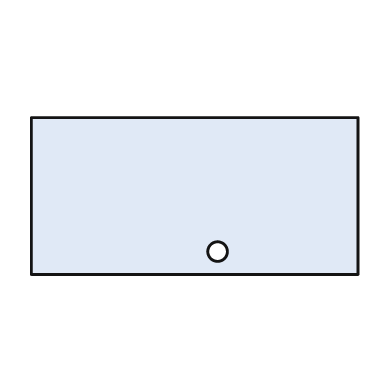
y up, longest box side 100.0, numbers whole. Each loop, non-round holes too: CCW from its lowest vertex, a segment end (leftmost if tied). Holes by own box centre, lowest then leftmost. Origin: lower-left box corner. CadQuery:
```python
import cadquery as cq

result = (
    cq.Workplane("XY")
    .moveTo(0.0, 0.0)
    .lineTo(100.0, 0.0)
    .lineTo(100.0, 48.0)
    .lineTo(0.0, 48.0)
    .close()
    .moveTo(57.0, 7.0)
    .circle(3.0)
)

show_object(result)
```